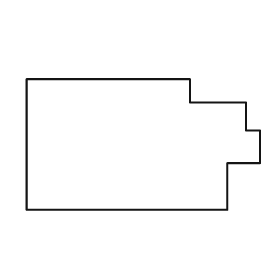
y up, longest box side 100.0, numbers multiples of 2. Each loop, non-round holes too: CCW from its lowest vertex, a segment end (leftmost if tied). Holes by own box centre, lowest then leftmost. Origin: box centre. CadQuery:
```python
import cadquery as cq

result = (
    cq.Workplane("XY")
    .moveTo(-50.0, -28.0)
    .lineTo(36.0, -28.0)
    .lineTo(36.0, -8.0)
    .lineTo(50.0, -8.0)
    .lineTo(50.0, 6.0)
    .lineTo(44.0, 6.0)
    .lineTo(44.0, 18.0)
    .lineTo(20.0, 18.0)
    .lineTo(20.0, 28.0)
    .lineTo(-50.0, 28.0)
    .close()
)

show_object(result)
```